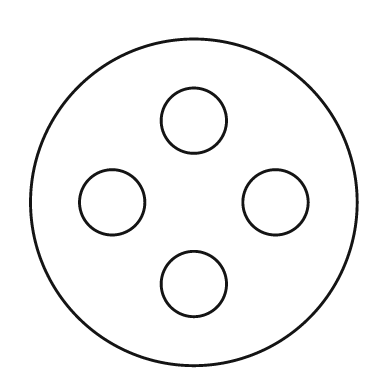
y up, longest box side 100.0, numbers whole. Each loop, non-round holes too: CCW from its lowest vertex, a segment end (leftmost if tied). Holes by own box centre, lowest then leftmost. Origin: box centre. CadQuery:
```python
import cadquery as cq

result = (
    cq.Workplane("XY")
    .moveTo(0.0, 0.0)
    .circle(50.0)
    .moveTo(0.0, -25.0)
    .circle(10.0)
    .moveTo(-25.0, 0.0)
    .circle(10.0)
    .moveTo(25.0, 0.0)
    .circle(10.0)
    .moveTo(0.0, 25.0)
    .circle(10.0)
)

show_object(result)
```